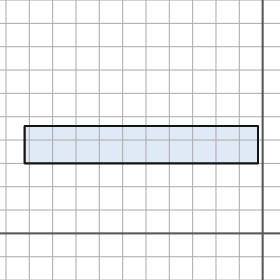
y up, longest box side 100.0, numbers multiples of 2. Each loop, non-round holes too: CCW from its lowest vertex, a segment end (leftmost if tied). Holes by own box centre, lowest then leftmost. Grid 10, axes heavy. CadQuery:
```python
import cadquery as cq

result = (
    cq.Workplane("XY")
    .moveTo(-102.0, 30.0)
    .lineTo(-2.0, 30.0)
    .lineTo(-2.0, 46.0)
    .lineTo(-102.0, 46.0)
    .close()
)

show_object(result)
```